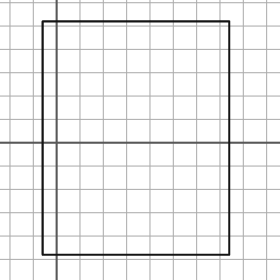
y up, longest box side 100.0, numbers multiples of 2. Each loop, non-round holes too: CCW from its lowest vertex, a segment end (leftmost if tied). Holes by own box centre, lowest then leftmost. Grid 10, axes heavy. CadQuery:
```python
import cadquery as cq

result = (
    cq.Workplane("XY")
    .moveTo(-6.0, -48.0)
    .lineTo(74.0, -48.0)
    .lineTo(74.0, 52.0)
    .lineTo(-6.0, 52.0)
    .close()
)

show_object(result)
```